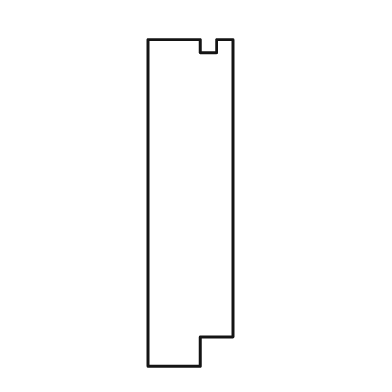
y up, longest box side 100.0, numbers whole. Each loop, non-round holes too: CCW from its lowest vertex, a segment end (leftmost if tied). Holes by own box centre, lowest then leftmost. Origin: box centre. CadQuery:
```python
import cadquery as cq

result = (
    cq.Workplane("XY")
    .moveTo(-13.0, -50.0)
    .lineTo(3.0, -50.0)
    .lineTo(3.0, -41.0)
    .lineTo(13.0, -41.0)
    .lineTo(13.0, 50.0)
    .lineTo(8.0, 50.0)
    .lineTo(8.0, 46.0)
    .lineTo(3.0, 46.0)
    .lineTo(3.0, 50.0)
    .lineTo(-13.0, 50.0)
    .close()
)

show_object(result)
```